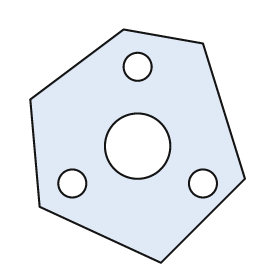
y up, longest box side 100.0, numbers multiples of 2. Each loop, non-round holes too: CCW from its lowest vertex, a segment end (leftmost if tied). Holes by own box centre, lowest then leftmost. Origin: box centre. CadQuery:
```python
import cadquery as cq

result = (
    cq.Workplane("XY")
    .moveTo(10.0, -50.0)
    .lineTo(46.0, -14.0)
    .lineTo(28.0, 44.0)
    .lineTo(-6.0, 50.0)
    .lineTo(-46.0, 20.0)
    .lineTo(-42.0, -26.0)
    .close()
    .moveTo(-28.0, -16.0)
    .circle(6.0)
    .moveTo(28.0, -16.0)
    .circle(6.0)
    .moveTo(0.0, 0.0)
    .circle(14.0)
    .moveTo(0.0, 34.0)
    .circle(6.0)
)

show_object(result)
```